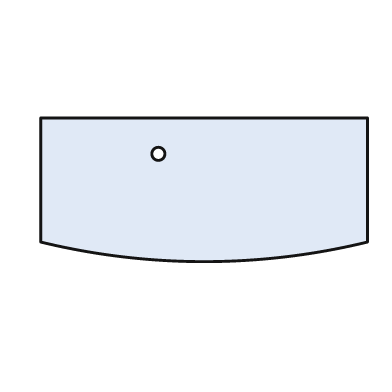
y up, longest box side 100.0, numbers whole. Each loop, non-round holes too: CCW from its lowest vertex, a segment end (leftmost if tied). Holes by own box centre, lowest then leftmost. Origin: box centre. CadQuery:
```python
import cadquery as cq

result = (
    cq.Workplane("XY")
    .moveTo(-50.0, -16.0)
    .threePointArc((0.0, -22.0), (50.0, -16.0))
    .lineTo(50.0, 22.0)
    .lineTo(-50.0, 22.0)
    .close()
    .moveTo(-14.0, 11.0)
    .circle(2.0)
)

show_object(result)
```